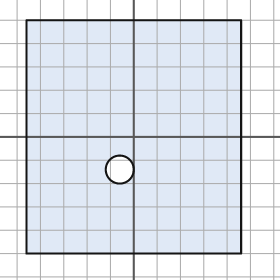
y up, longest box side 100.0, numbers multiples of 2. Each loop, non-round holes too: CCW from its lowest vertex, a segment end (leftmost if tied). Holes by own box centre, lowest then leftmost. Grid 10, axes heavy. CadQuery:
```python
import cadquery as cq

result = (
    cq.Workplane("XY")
    .moveTo(-46.0, -50.0)
    .lineTo(46.0, -50.0)
    .lineTo(46.0, 50.0)
    .lineTo(-46.0, 50.0)
    .close()
    .moveTo(-6.0, -14.0)
    .circle(6.0)
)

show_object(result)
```